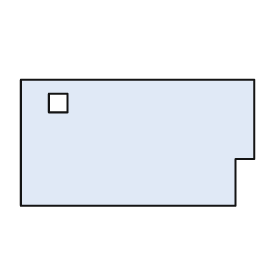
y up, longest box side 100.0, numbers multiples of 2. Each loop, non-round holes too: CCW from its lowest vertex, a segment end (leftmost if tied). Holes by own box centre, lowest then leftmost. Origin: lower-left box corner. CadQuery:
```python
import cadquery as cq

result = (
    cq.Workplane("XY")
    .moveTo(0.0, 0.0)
    .lineTo(92.0, 0.0)
    .lineTo(92.0, 20.0)
    .lineTo(100.0, 20.0)
    .lineTo(100.0, 54.0)
    .lineTo(0.0, 54.0)
    .close()
    .moveTo(12.0, 40.0)
    .lineTo(20.0, 40.0)
    .lineTo(20.0, 48.0)
    .lineTo(12.0, 48.0)
    .close()
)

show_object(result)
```